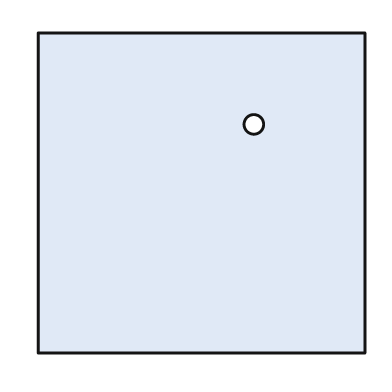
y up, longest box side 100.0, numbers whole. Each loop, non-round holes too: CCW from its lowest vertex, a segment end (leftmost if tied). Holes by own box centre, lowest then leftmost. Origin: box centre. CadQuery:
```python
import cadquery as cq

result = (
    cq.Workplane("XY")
    .moveTo(-50.0, -49.0)
    .lineTo(50.0, -49.0)
    .lineTo(50.0, 49.0)
    .lineTo(-50.0, 49.0)
    .close()
    .moveTo(16.0, 21.0)
    .circle(3.0)
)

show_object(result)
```